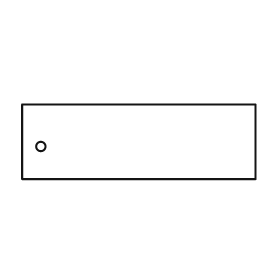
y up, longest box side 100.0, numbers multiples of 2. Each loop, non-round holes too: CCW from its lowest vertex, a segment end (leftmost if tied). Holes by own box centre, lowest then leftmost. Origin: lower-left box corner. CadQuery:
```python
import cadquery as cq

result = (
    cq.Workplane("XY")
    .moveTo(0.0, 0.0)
    .lineTo(100.0, 0.0)
    .lineTo(100.0, 32.0)
    .lineTo(0.0, 32.0)
    .close()
    .moveTo(8.0, 14.0)
    .circle(2.0)
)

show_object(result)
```